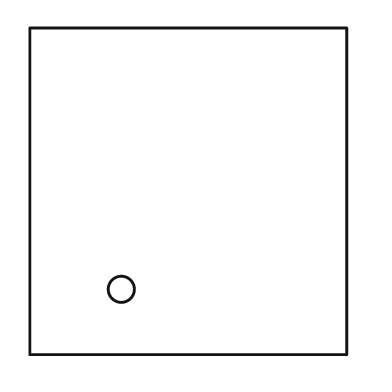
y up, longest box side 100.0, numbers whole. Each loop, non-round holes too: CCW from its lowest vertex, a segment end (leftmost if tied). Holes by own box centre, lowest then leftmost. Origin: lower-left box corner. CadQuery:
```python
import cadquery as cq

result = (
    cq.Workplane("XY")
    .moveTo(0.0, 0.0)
    .lineTo(97.0, 0.0)
    .lineTo(97.0, 100.0)
    .lineTo(0.0, 100.0)
    .close()
    .moveTo(28.0, 20.0)
    .circle(4.0)
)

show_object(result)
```